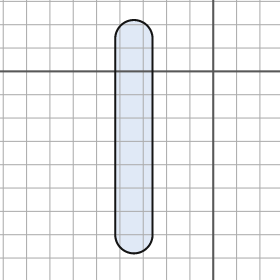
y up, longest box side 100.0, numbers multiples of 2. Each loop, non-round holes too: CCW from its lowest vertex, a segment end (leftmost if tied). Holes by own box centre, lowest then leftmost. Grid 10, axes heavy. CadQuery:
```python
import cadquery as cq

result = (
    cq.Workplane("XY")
    .moveTo(-42.0, -70.0)
    .threePointArc((-34.0, -78.0), (-26.0, -70.0))
    .lineTo(-26.0, 14.0)
    .threePointArc((-34.0, 22.0), (-42.0, 14.0))
    .close()
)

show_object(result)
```